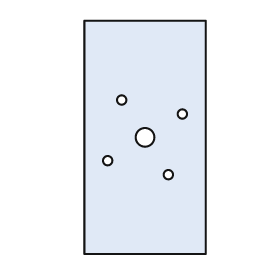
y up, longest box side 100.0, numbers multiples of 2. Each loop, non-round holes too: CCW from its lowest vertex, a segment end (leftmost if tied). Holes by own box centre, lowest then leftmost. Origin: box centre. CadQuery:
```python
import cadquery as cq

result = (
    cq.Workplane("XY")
    .moveTo(-26.0, -50.0)
    .lineTo(26.0, -50.0)
    .lineTo(26.0, 50.0)
    .lineTo(-26.0, 50.0)
    .close()
    .moveTo(10.0, -16.0)
    .circle(2.0)
    .moveTo(-16.0, -10.0)
    .circle(2.0)
    .moveTo(0.0, 0.0)
    .circle(4.0)
    .moveTo(16.0, 10.0)
    .circle(2.0)
    .moveTo(-10.0, 16.0)
    .circle(2.0)
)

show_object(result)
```